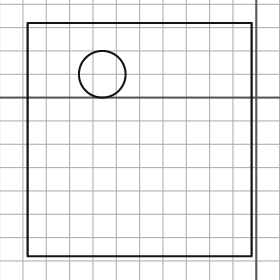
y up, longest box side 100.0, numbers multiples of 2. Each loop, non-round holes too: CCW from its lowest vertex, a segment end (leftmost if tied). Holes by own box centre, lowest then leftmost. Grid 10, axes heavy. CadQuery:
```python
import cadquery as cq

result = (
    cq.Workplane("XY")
    .moveTo(-98.0, -68.0)
    .lineTo(-2.0, -68.0)
    .lineTo(-2.0, 32.0)
    .lineTo(-98.0, 32.0)
    .close()
    .moveTo(-66.0, 10.0)
    .circle(10.0)
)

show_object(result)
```